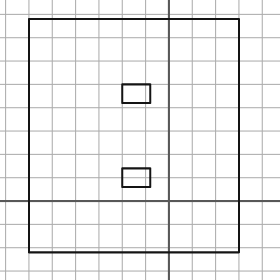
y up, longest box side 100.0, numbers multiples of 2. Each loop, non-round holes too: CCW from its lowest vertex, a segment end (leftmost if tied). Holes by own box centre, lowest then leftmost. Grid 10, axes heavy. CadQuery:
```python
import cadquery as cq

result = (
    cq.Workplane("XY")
    .moveTo(-60.0, -22.0)
    .lineTo(30.0, -22.0)
    .lineTo(30.0, 78.0)
    .lineTo(-60.0, 78.0)
    .close()
    .moveTo(-20.0, 6.0)
    .lineTo(-8.0, 6.0)
    .lineTo(-8.0, 14.0)
    .lineTo(-20.0, 14.0)
    .close()
    .moveTo(-20.0, 42.0)
    .lineTo(-8.0, 42.0)
    .lineTo(-8.0, 50.0)
    .lineTo(-20.0, 50.0)
    .close()
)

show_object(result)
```